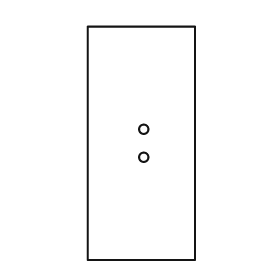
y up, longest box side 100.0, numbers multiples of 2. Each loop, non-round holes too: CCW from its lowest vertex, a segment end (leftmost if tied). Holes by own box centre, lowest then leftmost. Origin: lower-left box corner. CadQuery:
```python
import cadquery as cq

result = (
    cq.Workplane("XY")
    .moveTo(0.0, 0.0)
    .lineTo(46.0, 0.0)
    .lineTo(46.0, 100.0)
    .lineTo(0.0, 100.0)
    .close()
    .moveTo(24.0, 44.0)
    .circle(2.0)
    .moveTo(24.0, 56.0)
    .circle(2.0)
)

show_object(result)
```